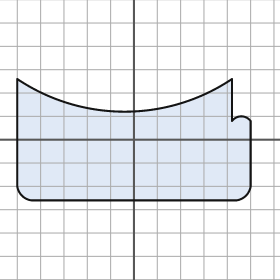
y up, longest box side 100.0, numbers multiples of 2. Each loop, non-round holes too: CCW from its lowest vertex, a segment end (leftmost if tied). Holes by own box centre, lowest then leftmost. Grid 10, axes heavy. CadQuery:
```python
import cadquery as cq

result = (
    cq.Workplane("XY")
    .moveTo(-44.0, -26.0)
    .lineTo(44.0, -26.0)
    .threePointArc((48.0, -24.0), (50.0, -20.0))
    .lineTo(50.0, 8.0)
    .threePointArc((46.0, 10.0), (42.0, 8.0))
    .lineTo(42.0, 26.0)
    .threePointArc((-4.0, 12.0), (-50.0, 26.0))
    .lineTo(-50.0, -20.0)
    .threePointArc((-48.0, -24.0), (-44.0, -26.0))
    .close()
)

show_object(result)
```